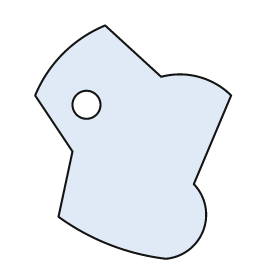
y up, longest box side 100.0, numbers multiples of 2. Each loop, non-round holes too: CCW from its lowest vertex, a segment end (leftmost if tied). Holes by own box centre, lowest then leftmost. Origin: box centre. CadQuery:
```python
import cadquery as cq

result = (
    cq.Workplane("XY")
    .moveTo(14.0, -50.0)
    .threePointArc((30.0, -38.0), (26.0, -18.0))
    .lineTo(42.0, 20.0)
    .threePointArc((28.0, 28.0), (12.0, 28.0))
    .lineTo(-12.0, 50.0)
    .threePointArc((-30.0, 38.0), (-42.0, 20.0))
    .lineTo(-26.0, -4.0)
    .lineTo(-32.0, -32.0)
    .threePointArc((-10.0, -44.0), (14.0, -50.0))
    .close()
    .moveTo(-20.0, 16.0)
    .circle(6.0)
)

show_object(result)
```